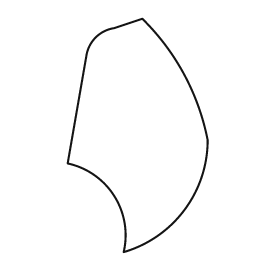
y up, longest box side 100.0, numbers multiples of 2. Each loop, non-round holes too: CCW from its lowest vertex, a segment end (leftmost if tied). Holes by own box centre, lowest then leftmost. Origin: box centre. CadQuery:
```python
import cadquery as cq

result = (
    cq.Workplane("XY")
    .moveTo(-6.0, -50.0)
    .threePointArc((20.0, -32.0), (30.0, -2.0))
    .threePointArc((20.0, 26.0), (2.0, 50.0))
    .lineTo(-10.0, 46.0)
    .threePointArc((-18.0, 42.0), (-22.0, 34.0))
    .lineTo(-30.0, -12.0)
    .threePointArc((-10.0, -26.0), (-6.0, -50.0))
    .close()
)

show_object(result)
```